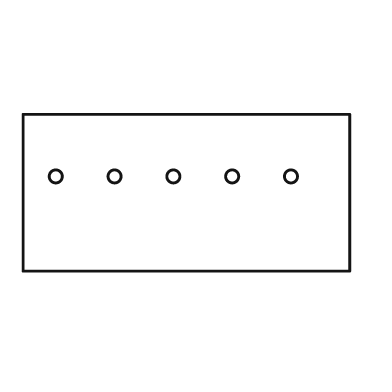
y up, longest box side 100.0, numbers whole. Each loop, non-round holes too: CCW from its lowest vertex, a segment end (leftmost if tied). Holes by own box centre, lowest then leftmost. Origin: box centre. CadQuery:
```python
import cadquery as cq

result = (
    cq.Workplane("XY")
    .moveTo(-50.0, -24.0)
    .lineTo(50.0, -24.0)
    .lineTo(50.0, 24.0)
    .lineTo(-50.0, 24.0)
    .close()
    .moveTo(-40.0, 5.0)
    .circle(2.0)
    .moveTo(-22.0, 5.0)
    .circle(2.0)
    .moveTo(-4.0, 5.0)
    .circle(2.0)
    .moveTo(14.0, 5.0)
    .circle(2.0)
    .moveTo(32.0, 5.0)
    .circle(2.0)
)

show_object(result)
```